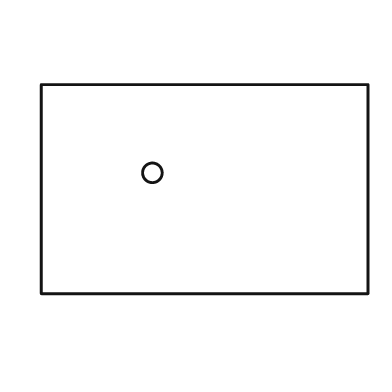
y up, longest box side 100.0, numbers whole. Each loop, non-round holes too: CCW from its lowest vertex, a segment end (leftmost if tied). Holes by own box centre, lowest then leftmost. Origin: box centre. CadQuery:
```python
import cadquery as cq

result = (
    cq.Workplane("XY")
    .moveTo(-50.0, -32.0)
    .lineTo(50.0, -32.0)
    .lineTo(50.0, 32.0)
    .lineTo(-50.0, 32.0)
    .close()
    .moveTo(-16.0, 5.0)
    .circle(3.0)
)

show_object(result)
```